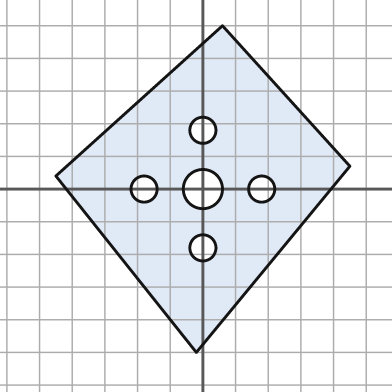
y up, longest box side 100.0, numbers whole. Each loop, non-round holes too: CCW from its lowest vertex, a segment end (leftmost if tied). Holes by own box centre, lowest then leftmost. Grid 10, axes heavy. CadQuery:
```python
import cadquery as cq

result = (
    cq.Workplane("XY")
    .moveTo(-2.0, -50.0)
    .lineTo(45.0, 7.0)
    .lineTo(6.0, 50.0)
    .lineTo(-45.0, 4.0)
    .close()
    .moveTo(0.0, -18.0)
    .circle(4.0)
    .moveTo(-18.0, 0.0)
    .circle(4.0)
    .moveTo(0.0, 0.0)
    .circle(6.0)
    .moveTo(18.0, 0.0)
    .circle(4.0)
    .moveTo(0.0, 18.0)
    .circle(4.0)
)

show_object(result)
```